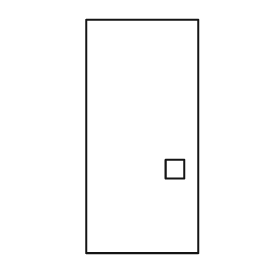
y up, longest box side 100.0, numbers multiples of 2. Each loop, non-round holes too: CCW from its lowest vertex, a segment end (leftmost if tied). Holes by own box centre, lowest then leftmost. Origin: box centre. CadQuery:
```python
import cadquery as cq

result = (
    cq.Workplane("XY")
    .moveTo(-24.0, -50.0)
    .lineTo(24.0, -50.0)
    .lineTo(24.0, 50.0)
    .lineTo(-24.0, 50.0)
    .close()
    .moveTo(10.0, -18.0)
    .lineTo(18.0, -18.0)
    .lineTo(18.0, -10.0)
    .lineTo(10.0, -10.0)
    .close()
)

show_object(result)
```